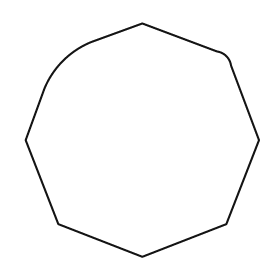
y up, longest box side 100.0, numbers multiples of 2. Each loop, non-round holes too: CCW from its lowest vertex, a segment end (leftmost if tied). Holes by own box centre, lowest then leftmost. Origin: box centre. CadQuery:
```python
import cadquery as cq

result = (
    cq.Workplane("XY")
    .moveTo(0.0, -50.0)
    .lineTo(36.0, -36.0)
    .lineTo(50.0, 0.0)
    .lineTo(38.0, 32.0)
    .threePointArc((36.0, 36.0), (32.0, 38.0))
    .lineTo(0.0, 50.0)
    .lineTo(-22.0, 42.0)
    .threePointArc((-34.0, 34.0), (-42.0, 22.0))
    .lineTo(-50.0, 0.0)
    .lineTo(-36.0, -36.0)
    .close()
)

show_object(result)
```